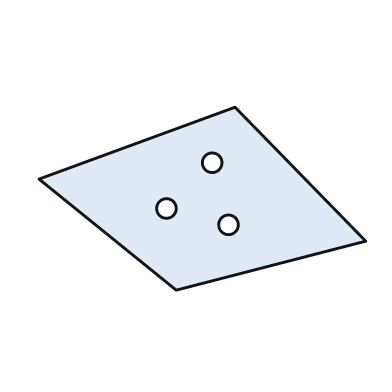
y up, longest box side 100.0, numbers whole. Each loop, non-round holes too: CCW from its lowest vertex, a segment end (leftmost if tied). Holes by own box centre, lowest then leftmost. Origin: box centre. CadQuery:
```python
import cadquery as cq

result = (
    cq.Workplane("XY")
    .moveTo(-8.0, -28.0)
    .lineTo(50.0, -13.0)
    .lineTo(10.0, 28.0)
    .lineTo(-50.0, 6.0)
    .close()
    .moveTo(8.0, -8.0)
    .circle(3.0)
    .moveTo(-11.0, -3.0)
    .circle(3.0)
    .moveTo(3.0, 11.0)
    .circle(3.0)
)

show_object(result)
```